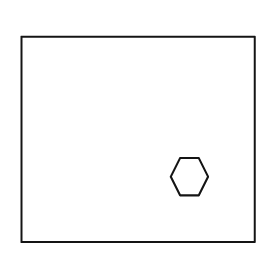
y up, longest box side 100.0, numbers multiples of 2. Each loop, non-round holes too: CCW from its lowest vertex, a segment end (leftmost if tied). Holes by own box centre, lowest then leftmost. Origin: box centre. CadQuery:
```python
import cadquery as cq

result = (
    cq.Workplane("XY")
    .moveTo(-50.0, -44.0)
    .lineTo(50.0, -44.0)
    .lineTo(50.0, 44.0)
    .lineTo(-50.0, 44.0)
    .close()
    .moveTo(18.0, -24.0)
    .lineTo(26.0, -24.0)
    .lineTo(30.0, -16.0)
    .lineTo(26.0, -8.0)
    .lineTo(18.0, -8.0)
    .lineTo(14.0, -16.0)
    .close()
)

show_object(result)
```